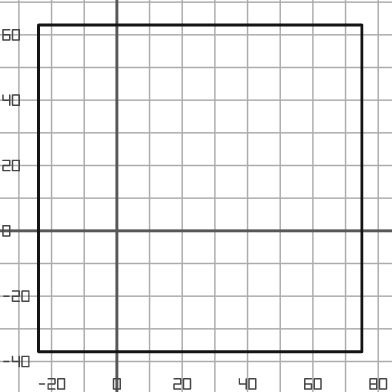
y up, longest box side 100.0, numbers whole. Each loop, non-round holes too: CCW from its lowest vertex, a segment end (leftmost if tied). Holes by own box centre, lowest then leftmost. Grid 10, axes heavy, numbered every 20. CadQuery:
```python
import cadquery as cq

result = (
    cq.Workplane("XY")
    .moveTo(-24.0, -37.0)
    .lineTo(75.0, -37.0)
    .lineTo(75.0, 63.0)
    .lineTo(-24.0, 63.0)
    .close()
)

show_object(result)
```